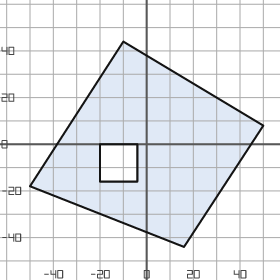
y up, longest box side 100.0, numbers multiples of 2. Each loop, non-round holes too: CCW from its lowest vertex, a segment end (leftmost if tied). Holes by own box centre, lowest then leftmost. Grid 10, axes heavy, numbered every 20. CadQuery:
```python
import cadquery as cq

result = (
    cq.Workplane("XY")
    .moveTo(16.0, -44.0)
    .lineTo(50.0, 8.0)
    .lineTo(-10.0, 44.0)
    .lineTo(-50.0, -18.0)
    .close()
    .moveTo(-20.0, -16.0)
    .lineTo(-4.0, -16.0)
    .lineTo(-4.0, 0.0)
    .lineTo(-20.0, 0.0)
    .close()
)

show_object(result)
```